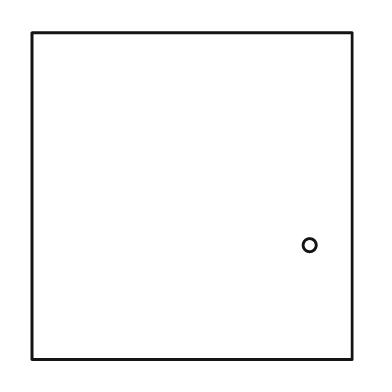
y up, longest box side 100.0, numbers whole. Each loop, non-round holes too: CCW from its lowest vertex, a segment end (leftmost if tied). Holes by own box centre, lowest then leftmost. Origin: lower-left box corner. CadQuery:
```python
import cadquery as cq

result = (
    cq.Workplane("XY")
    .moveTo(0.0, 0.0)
    .lineTo(98.0, 0.0)
    .lineTo(98.0, 100.0)
    .lineTo(0.0, 100.0)
    .close()
    .moveTo(85.0, 35.0)
    .circle(2.0)
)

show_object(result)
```